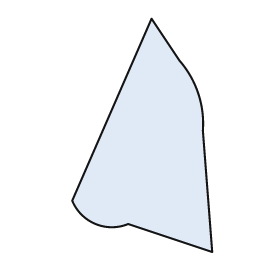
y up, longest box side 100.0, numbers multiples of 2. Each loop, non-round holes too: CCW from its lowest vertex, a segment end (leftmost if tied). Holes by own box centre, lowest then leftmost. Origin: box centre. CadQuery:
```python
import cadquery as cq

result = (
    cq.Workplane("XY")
    .moveTo(30.0, -50.0)
    .lineTo(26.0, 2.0)
    .threePointArc((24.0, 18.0), (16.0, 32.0))
    .lineTo(4.0, 50.0)
    .lineTo(-30.0, -28.0)
    .threePointArc((-20.0, -38.0), (-6.0, -38.0))
    .close()
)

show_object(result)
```